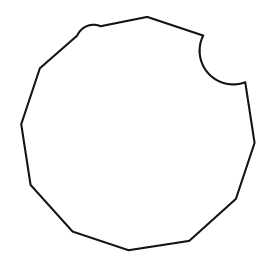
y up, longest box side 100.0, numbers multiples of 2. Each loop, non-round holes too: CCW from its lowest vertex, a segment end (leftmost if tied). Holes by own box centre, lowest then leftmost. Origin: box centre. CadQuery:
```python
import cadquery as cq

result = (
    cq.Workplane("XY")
    .moveTo(-4.0, -50.0)
    .lineTo(22.0, -46.0)
    .lineTo(42.0, -28.0)
    .lineTo(50.0, -4.0)
    .lineTo(46.0, 22.0)
    .threePointArc((30.0, 26.0), (28.0, 42.0))
    .lineTo(4.0, 50.0)
    .lineTo(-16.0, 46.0)
    .threePointArc((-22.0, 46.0), (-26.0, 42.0))
    .lineTo(-42.0, 28.0)
    .lineTo(-50.0, 4.0)
    .lineTo(-46.0, -22.0)
    .lineTo(-28.0, -42.0)
    .close()
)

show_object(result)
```